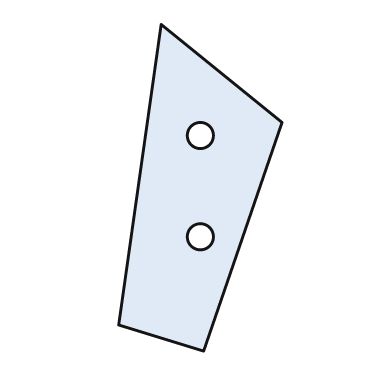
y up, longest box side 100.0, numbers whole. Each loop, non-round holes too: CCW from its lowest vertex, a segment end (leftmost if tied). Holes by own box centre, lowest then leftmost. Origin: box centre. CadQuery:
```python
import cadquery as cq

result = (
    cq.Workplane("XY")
    .moveTo(1.0, -50.0)
    .lineTo(25.0, 20.0)
    .lineTo(-12.0, 50.0)
    .lineTo(-25.0, -42.0)
    .close()
    .moveTo(0.0, -15.0)
    .circle(4.0)
    .moveTo(0.0, 16.0)
    .circle(4.0)
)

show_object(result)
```